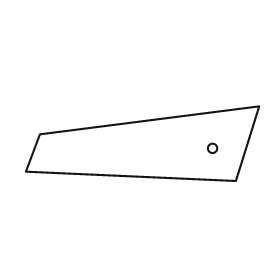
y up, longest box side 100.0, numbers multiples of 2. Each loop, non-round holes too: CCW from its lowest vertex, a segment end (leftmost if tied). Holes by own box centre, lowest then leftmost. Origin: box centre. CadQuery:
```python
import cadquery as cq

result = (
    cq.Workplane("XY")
    .moveTo(40.0, -16.0)
    .lineTo(50.0, 16.0)
    .lineTo(-44.0, 4.0)
    .lineTo(-50.0, -12.0)
    .close()
    .moveTo(30.0, -2.0)
    .circle(2.0)
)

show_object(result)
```